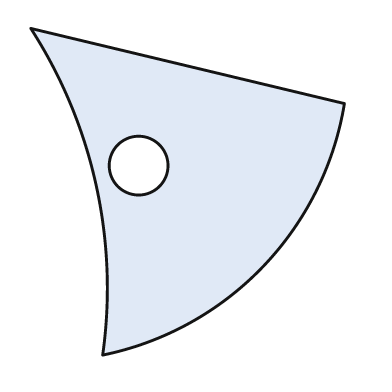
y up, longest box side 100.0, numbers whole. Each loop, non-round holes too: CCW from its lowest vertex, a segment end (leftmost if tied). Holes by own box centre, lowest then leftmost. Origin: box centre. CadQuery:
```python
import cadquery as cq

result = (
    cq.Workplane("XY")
    .moveTo(-26.0, -50.0)
    .threePointArc((23.0, -23.0), (48.0, 27.0))
    .lineTo(-48.0, 50.0)
    .threePointArc((-28.0, 2.0), (-26.0, -50.0))
    .close()
    .moveTo(-15.0, 8.0)
    .circle(9.0)
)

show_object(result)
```